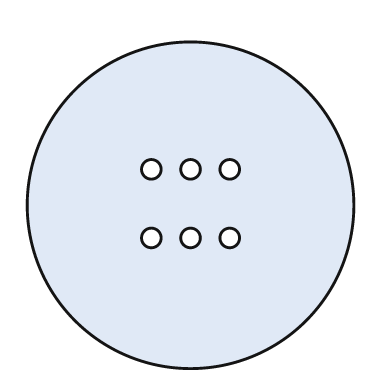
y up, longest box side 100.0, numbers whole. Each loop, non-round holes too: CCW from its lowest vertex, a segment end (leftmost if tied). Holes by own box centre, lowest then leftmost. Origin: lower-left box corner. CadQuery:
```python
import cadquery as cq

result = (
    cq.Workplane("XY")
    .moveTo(50.0, 50.0)
    .circle(50.0)
    .moveTo(38.0, 40.0)
    .circle(3.0)
    .moveTo(50.0, 40.0)
    .circle(3.0)
    .moveTo(62.0, 40.0)
    .circle(3.0)
    .moveTo(38.0, 61.0)
    .circle(3.0)
    .moveTo(50.0, 61.0)
    .circle(3.0)
    .moveTo(62.0, 61.0)
    .circle(3.0)
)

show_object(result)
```